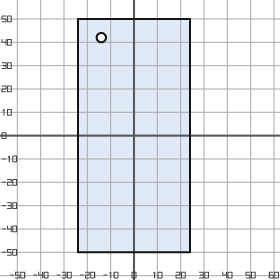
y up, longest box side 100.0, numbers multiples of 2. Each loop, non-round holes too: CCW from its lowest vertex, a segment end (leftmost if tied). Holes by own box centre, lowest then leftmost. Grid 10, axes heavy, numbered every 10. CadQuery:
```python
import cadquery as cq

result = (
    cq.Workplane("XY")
    .moveTo(-24.0, -50.0)
    .lineTo(24.0, -50.0)
    .lineTo(24.0, 50.0)
    .lineTo(-24.0, 50.0)
    .close()
    .moveTo(-14.0, 42.0)
    .circle(2.0)
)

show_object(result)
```